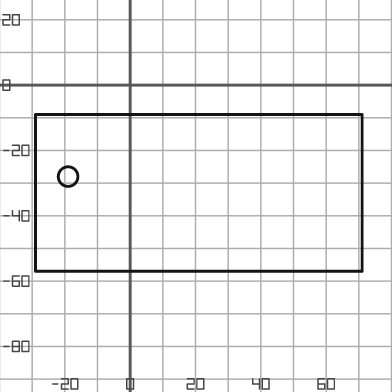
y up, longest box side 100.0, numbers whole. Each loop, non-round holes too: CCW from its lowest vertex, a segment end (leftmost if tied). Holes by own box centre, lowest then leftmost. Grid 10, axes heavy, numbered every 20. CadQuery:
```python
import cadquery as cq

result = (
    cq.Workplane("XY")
    .moveTo(-29.0, -57.0)
    .lineTo(71.0, -57.0)
    .lineTo(71.0, -9.0)
    .lineTo(-29.0, -9.0)
    .close()
    .moveTo(-19.0, -28.0)
    .circle(3.0)
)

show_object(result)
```